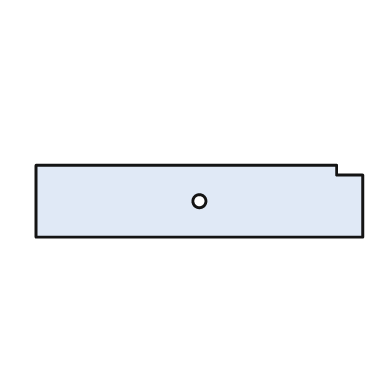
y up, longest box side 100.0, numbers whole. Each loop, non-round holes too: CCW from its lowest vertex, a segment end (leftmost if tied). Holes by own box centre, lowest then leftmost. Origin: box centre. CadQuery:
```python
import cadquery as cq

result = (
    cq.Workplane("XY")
    .moveTo(-50.0, -11.0)
    .lineTo(50.0, -11.0)
    .lineTo(50.0, 8.0)
    .lineTo(42.0, 8.0)
    .lineTo(42.0, 11.0)
    .lineTo(-50.0, 11.0)
    .close()
    .moveTo(0.0, 0.0)
    .circle(2.0)
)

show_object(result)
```